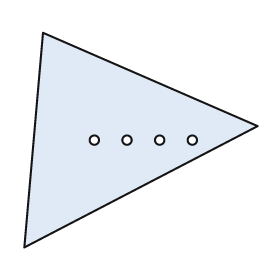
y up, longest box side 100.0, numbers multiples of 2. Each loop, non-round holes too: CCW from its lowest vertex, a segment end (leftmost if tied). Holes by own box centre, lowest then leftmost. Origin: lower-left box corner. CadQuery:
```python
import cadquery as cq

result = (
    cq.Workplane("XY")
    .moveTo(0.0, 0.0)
    .lineTo(100.0, 52.0)
    .lineTo(8.0, 92.0)
    .close()
    .moveTo(30.0, 46.0)
    .circle(2.0)
    .moveTo(44.0, 46.0)
    .circle(2.0)
    .moveTo(58.0, 46.0)
    .circle(2.0)
    .moveTo(72.0, 46.0)
    .circle(2.0)
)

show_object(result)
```